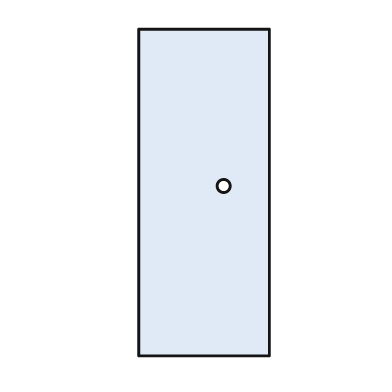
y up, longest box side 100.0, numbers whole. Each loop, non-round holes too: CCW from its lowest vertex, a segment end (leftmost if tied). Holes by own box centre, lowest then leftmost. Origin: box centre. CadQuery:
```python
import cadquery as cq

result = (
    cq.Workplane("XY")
    .moveTo(-20.0, -50.0)
    .lineTo(20.0, -50.0)
    .lineTo(20.0, 50.0)
    .lineTo(-20.0, 50.0)
    .close()
    .moveTo(6.0, 2.0)
    .circle(2.0)
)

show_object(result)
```